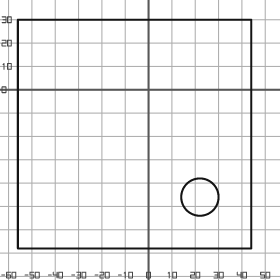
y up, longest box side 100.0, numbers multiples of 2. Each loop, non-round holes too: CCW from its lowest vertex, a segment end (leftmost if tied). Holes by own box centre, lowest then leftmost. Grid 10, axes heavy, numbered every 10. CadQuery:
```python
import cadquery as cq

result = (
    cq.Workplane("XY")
    .moveTo(-56.0, -68.0)
    .lineTo(44.0, -68.0)
    .lineTo(44.0, 30.0)
    .lineTo(-56.0, 30.0)
    .close()
    .moveTo(22.0, -46.0)
    .circle(8.0)
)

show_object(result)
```